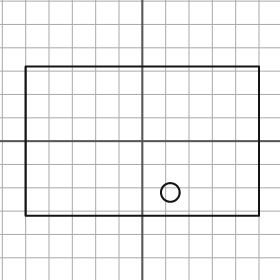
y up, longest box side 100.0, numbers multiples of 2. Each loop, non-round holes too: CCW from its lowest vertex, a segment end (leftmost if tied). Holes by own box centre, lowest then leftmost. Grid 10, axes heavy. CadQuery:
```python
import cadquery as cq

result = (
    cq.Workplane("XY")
    .moveTo(-50.0, -32.0)
    .lineTo(50.0, -32.0)
    .lineTo(50.0, 32.0)
    .lineTo(-50.0, 32.0)
    .close()
    .moveTo(12.0, -22.0)
    .circle(4.0)
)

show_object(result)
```